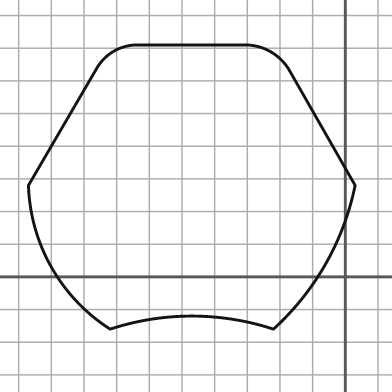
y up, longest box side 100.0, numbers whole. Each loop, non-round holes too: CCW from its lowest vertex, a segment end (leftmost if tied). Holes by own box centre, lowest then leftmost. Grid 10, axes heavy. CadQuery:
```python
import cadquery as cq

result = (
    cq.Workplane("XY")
    .moveTo(-72.0, -16.0)
    .threePointArc((-47.0, -12.0), (-22.0, -16.0))
    .threePointArc((-6.0, 4.0), (3.0, 28.0))
    .lineTo(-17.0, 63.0)
    .threePointArc((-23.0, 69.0), (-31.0, 71.0))
    .lineTo(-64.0, 71.0)
    .threePointArc((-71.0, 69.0), (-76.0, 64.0))
    .lineTo(-97.0, 28.0)
    .threePointArc((-90.0, 3.0), (-72.0, -16.0))
    .close()
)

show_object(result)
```